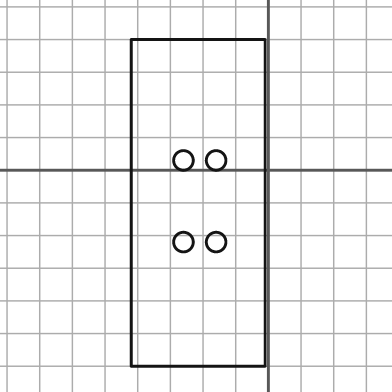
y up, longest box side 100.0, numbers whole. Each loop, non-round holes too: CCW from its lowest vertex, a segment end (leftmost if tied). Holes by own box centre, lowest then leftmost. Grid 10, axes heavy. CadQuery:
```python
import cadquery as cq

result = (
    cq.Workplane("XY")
    .moveTo(-42.0, -60.0)
    .lineTo(-1.0, -60.0)
    .lineTo(-1.0, 40.0)
    .lineTo(-42.0, 40.0)
    .close()
    .moveTo(-26.0, -22.0)
    .circle(3.0)
    .moveTo(-16.0, -22.0)
    .circle(3.0)
    .moveTo(-26.0, 3.0)
    .circle(3.0)
    .moveTo(-16.0, 3.0)
    .circle(3.0)
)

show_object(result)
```